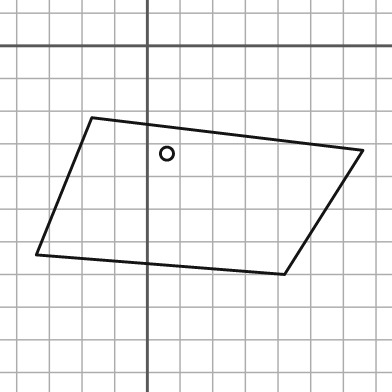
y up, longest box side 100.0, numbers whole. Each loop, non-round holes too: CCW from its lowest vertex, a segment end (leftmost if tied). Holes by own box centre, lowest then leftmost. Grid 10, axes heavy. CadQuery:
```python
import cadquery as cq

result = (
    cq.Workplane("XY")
    .moveTo(42.0, -70.0)
    .lineTo(66.0, -32.0)
    .lineTo(-17.0, -22.0)
    .lineTo(-34.0, -64.0)
    .close()
    .moveTo(6.0, -33.0)
    .circle(2.0)
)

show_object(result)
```